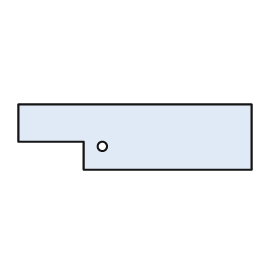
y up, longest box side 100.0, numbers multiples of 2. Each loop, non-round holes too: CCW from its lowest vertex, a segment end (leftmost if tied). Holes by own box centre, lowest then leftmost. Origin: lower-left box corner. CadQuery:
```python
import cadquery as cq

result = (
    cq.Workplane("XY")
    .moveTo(28.0, 0.0)
    .lineTo(100.0, 0.0)
    .lineTo(100.0, 28.0)
    .lineTo(0.0, 28.0)
    .lineTo(0.0, 12.0)
    .lineTo(28.0, 12.0)
    .close()
    .moveTo(36.0, 10.0)
    .circle(2.0)
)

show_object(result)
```